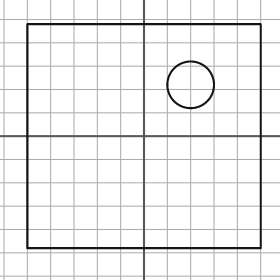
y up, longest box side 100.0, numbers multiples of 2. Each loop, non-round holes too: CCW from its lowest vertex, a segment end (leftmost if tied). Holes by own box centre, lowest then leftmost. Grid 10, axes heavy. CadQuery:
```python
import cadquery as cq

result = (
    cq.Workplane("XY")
    .moveTo(-50.0, -48.0)
    .lineTo(50.0, -48.0)
    .lineTo(50.0, 48.0)
    .lineTo(-50.0, 48.0)
    .close()
    .moveTo(20.0, 22.0)
    .circle(10.0)
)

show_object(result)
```